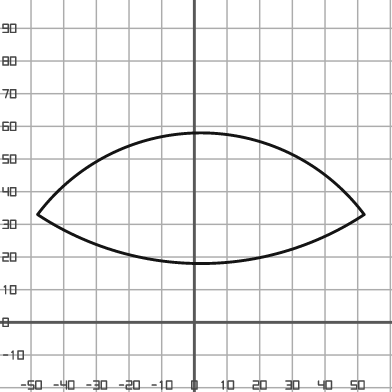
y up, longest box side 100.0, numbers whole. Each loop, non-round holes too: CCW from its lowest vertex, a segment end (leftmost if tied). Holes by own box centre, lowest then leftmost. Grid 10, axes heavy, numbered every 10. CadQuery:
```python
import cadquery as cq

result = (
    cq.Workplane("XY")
    .moveTo(-48.0, 33.0)
    .threePointArc((2.0, 18.0), (52.0, 33.0))
    .threePointArc((2.0, 58.0), (-48.0, 33.0))
    .close()
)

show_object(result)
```